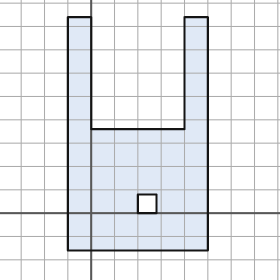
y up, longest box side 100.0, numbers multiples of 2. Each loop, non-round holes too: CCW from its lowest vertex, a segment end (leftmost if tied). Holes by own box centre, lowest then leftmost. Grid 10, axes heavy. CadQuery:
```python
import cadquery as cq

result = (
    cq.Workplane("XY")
    .moveTo(-10.0, -16.0)
    .lineTo(50.0, -16.0)
    .lineTo(50.0, 84.0)
    .lineTo(40.0, 84.0)
    .lineTo(40.0, 36.0)
    .lineTo(0.0, 36.0)
    .lineTo(0.0, 84.0)
    .lineTo(-10.0, 84.0)
    .close()
    .moveTo(20.0, 0.0)
    .lineTo(28.0, 0.0)
    .lineTo(28.0, 8.0)
    .lineTo(20.0, 8.0)
    .close()
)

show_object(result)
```